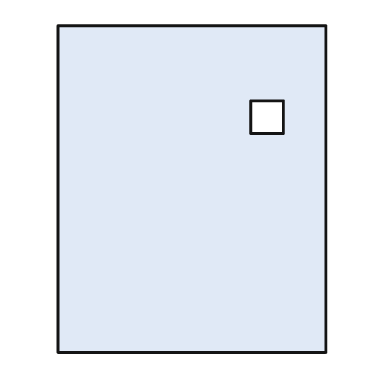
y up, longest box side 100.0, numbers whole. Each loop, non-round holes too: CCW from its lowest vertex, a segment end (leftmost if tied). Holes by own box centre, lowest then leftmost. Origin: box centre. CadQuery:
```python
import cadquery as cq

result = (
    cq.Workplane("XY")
    .moveTo(-41.0, -50.0)
    .lineTo(41.0, -50.0)
    .lineTo(41.0, 50.0)
    .lineTo(-41.0, 50.0)
    .close()
    .moveTo(18.0, 17.0)
    .lineTo(28.0, 17.0)
    .lineTo(28.0, 27.0)
    .lineTo(18.0, 27.0)
    .close()
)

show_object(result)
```